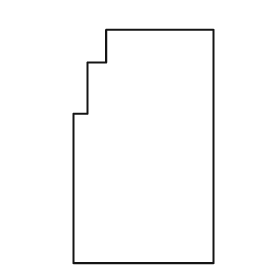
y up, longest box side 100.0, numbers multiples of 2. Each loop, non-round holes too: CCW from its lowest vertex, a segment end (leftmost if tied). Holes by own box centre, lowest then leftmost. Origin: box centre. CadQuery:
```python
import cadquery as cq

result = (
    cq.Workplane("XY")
    .moveTo(-30.0, -50.0)
    .lineTo(30.0, -50.0)
    .lineTo(30.0, 50.0)
    .lineTo(-16.0, 50.0)
    .lineTo(-16.0, 36.0)
    .lineTo(-24.0, 36.0)
    .lineTo(-24.0, 14.0)
    .lineTo(-30.0, 14.0)
    .close()
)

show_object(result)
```